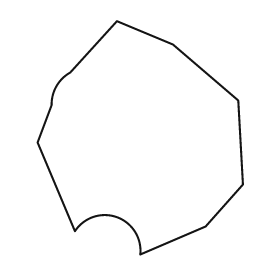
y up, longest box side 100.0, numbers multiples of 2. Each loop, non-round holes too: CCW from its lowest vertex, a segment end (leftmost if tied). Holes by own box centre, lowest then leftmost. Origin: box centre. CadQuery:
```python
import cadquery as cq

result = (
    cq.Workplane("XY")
    .moveTo(0.0, -50.0)
    .lineTo(28.0, -38.0)
    .lineTo(44.0, -20.0)
    .lineTo(42.0, 16.0)
    .lineTo(14.0, 40.0)
    .lineTo(-10.0, 50.0)
    .lineTo(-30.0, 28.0)
    .threePointArc((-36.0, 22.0), (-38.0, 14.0))
    .lineTo(-44.0, -2.0)
    .lineTo(-28.0, -40.0)
    .threePointArc((-10.0, -34.0), (0.0, -50.0))
    .close()
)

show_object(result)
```